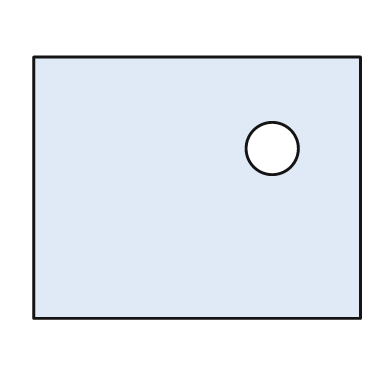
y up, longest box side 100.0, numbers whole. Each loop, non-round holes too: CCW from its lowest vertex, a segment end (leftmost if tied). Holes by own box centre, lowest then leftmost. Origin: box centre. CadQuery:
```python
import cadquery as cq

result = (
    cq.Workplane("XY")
    .moveTo(-50.0, -40.0)
    .lineTo(50.0, -40.0)
    .lineTo(50.0, 40.0)
    .lineTo(-50.0, 40.0)
    .close()
    .moveTo(23.0, 12.0)
    .circle(8.0)
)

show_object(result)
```